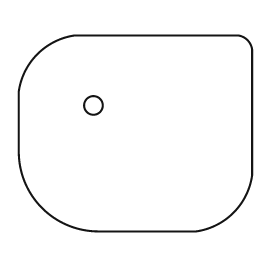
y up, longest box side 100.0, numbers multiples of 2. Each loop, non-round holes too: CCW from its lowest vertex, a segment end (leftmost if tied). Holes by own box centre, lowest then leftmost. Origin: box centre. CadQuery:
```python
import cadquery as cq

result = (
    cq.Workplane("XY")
    .moveTo(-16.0, -42.0)
    .lineTo(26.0, -42.0)
    .threePointArc((42.0, -34.0), (50.0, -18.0))
    .lineTo(50.0, 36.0)
    .threePointArc((48.0, 40.0), (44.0, 42.0))
    .lineTo(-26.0, 42.0)
    .threePointArc((-42.0, 34.0), (-50.0, 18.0))
    .lineTo(-50.0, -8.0)
    .threePointArc((-40.0, -32.0), (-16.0, -42.0))
    .close()
    .moveTo(-18.0, 12.0)
    .circle(4.0)
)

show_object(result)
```